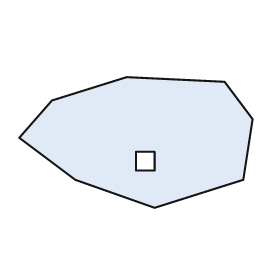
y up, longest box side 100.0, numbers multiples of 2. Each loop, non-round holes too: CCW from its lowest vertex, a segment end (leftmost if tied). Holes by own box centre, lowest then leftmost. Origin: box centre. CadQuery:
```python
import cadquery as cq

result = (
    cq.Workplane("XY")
    .moveTo(8.0, -28.0)
    .lineTo(46.0, -16.0)
    .lineTo(50.0, 10.0)
    .lineTo(38.0, 26.0)
    .lineTo(-4.0, 28.0)
    .lineTo(-36.0, 18.0)
    .lineTo(-50.0, 2.0)
    .lineTo(-26.0, -16.0)
    .close()
    .moveTo(0.0, -12.0)
    .lineTo(8.0, -12.0)
    .lineTo(8.0, -4.0)
    .lineTo(0.0, -4.0)
    .close()
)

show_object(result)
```